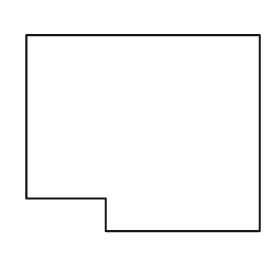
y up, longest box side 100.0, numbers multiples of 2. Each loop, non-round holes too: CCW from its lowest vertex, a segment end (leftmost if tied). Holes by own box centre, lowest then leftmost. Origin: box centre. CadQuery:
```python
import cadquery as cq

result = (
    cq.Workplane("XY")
    .moveTo(-16.0, -42.0)
    .lineTo(50.0, -42.0)
    .lineTo(50.0, 42.0)
    .lineTo(-50.0, 42.0)
    .lineTo(-50.0, -28.0)
    .lineTo(-16.0, -28.0)
    .close()
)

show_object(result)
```